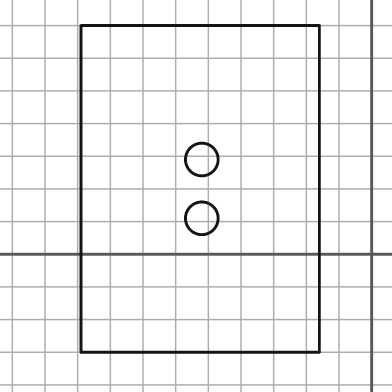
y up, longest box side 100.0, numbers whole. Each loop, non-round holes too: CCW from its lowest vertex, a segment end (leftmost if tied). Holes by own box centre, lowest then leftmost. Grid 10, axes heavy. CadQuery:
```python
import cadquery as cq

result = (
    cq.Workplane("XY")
    .moveTo(-89.0, -30.0)
    .lineTo(-16.0, -30.0)
    .lineTo(-16.0, 70.0)
    .lineTo(-89.0, 70.0)
    .close()
    .moveTo(-52.0, 11.0)
    .circle(5.0)
    .moveTo(-52.0, 29.0)
    .circle(5.0)
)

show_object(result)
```